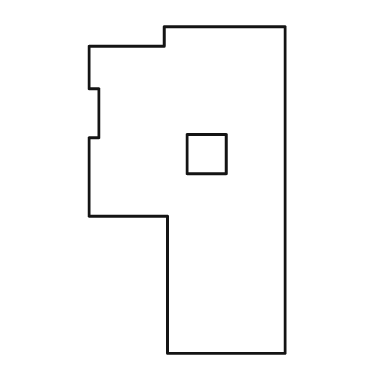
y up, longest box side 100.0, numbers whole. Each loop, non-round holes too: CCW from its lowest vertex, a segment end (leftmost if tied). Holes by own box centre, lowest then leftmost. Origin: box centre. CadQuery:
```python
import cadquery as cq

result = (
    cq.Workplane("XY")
    .moveTo(-6.0, -50.0)
    .lineTo(30.0, -50.0)
    .lineTo(30.0, 50.0)
    .lineTo(-7.0, 50.0)
    .lineTo(-7.0, 44.0)
    .lineTo(-30.0, 44.0)
    .lineTo(-30.0, 31.0)
    .lineTo(-27.0, 31.0)
    .lineTo(-27.0, 16.0)
    .lineTo(-30.0, 16.0)
    .lineTo(-30.0, -8.0)
    .lineTo(-6.0, -8.0)
    .close()
    .moveTo(0.0, 5.0)
    .lineTo(12.0, 5.0)
    .lineTo(12.0, 17.0)
    .lineTo(0.0, 17.0)
    .close()
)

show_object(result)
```